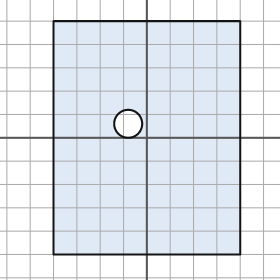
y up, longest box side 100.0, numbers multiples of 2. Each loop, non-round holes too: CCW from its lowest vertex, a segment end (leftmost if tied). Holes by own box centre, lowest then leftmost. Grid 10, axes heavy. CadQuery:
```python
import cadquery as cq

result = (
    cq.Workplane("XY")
    .moveTo(-40.0, -50.0)
    .lineTo(40.0, -50.0)
    .lineTo(40.0, 50.0)
    .lineTo(-40.0, 50.0)
    .close()
    .moveTo(-8.0, 6.0)
    .circle(6.0)
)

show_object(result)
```